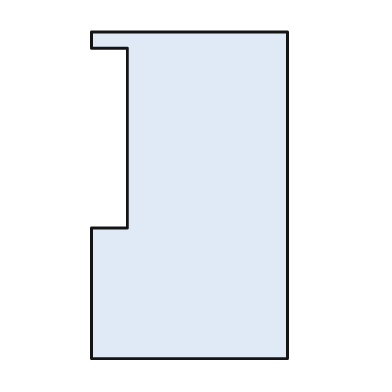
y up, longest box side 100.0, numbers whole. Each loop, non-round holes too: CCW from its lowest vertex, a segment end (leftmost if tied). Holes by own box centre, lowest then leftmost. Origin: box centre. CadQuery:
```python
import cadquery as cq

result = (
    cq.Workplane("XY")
    .moveTo(-30.0, -50.0)
    .lineTo(30.0, -50.0)
    .lineTo(30.0, 50.0)
    .lineTo(-30.0, 50.0)
    .lineTo(-30.0, 45.0)
    .lineTo(-19.0, 45.0)
    .lineTo(-19.0, -10.0)
    .lineTo(-30.0, -10.0)
    .close()
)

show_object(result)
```